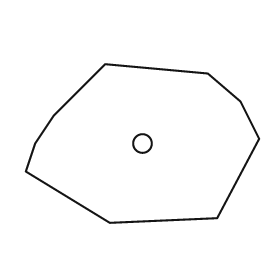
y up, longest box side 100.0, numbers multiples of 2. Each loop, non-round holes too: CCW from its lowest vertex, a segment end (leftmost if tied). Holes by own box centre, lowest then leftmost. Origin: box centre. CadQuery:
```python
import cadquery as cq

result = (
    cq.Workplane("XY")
    .moveTo(-14.0, -34.0)
    .lineTo(32.0, -32.0)
    .lineTo(50.0, 2.0)
    .lineTo(42.0, 18.0)
    .lineTo(28.0, 30.0)
    .lineTo(-16.0, 34.0)
    .lineTo(-38.0, 12.0)
    .lineTo(-46.0, 0.0)
    .lineTo(-50.0, -12.0)
    .close()
    .moveTo(0.0, 0.0)
    .circle(4.0)
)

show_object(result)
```